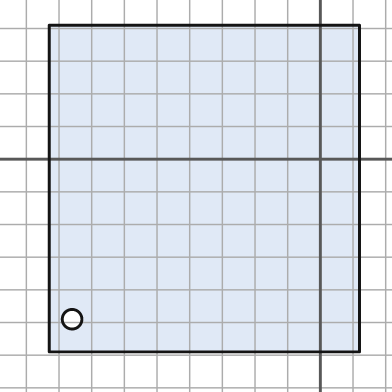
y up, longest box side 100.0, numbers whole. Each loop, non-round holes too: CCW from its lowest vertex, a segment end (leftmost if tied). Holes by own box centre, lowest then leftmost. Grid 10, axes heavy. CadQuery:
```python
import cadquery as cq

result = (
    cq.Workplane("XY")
    .moveTo(-83.0, -59.0)
    .lineTo(12.0, -59.0)
    .lineTo(12.0, 41.0)
    .lineTo(-83.0, 41.0)
    .close()
    .moveTo(-76.0, -49.0)
    .circle(3.0)
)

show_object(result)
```